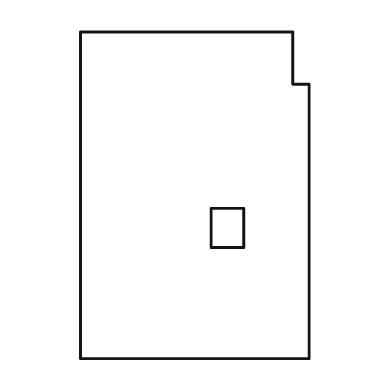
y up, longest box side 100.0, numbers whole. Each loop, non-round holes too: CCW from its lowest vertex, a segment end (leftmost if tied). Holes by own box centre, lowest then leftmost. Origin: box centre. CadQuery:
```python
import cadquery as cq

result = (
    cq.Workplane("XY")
    .moveTo(-35.0, -50.0)
    .lineTo(35.0, -50.0)
    .lineTo(35.0, 34.0)
    .lineTo(30.0, 34.0)
    .lineTo(30.0, 50.0)
    .lineTo(-35.0, 50.0)
    .close()
    .moveTo(5.0, -16.0)
    .lineTo(15.0, -16.0)
    .lineTo(15.0, -4.0)
    .lineTo(5.0, -4.0)
    .close()
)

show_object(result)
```